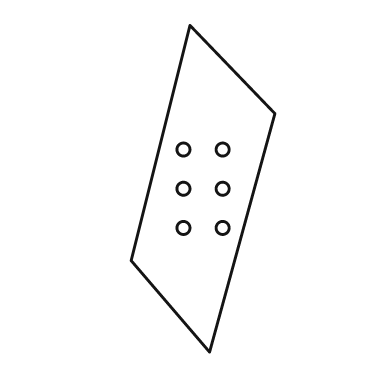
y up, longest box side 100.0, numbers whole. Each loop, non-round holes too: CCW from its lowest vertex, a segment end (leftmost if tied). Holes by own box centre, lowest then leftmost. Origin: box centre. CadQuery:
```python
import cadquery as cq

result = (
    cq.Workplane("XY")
    .moveTo(2.0, -50.0)
    .lineTo(22.0, 23.0)
    .lineTo(-4.0, 50.0)
    .lineTo(-22.0, -22.0)
    .close()
    .moveTo(-6.0, -12.0)
    .circle(2.0)
    .moveTo(6.0, -12.0)
    .circle(2.0)
    .moveTo(-6.0, 0.0)
    .circle(2.0)
    .moveTo(6.0, 0.0)
    .circle(2.0)
    .moveTo(-6.0, 12.0)
    .circle(2.0)
    .moveTo(6.0, 12.0)
    .circle(2.0)
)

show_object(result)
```